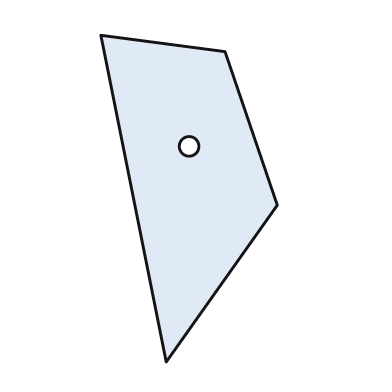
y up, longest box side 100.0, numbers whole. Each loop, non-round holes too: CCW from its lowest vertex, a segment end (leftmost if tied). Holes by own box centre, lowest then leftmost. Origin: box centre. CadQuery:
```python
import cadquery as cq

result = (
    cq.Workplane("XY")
    .moveTo(-7.0, -50.0)
    .lineTo(27.0, -2.0)
    .lineTo(11.0, 45.0)
    .lineTo(-27.0, 50.0)
    .close()
    .moveTo(0.0, 16.0)
    .circle(3.0)
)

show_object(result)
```